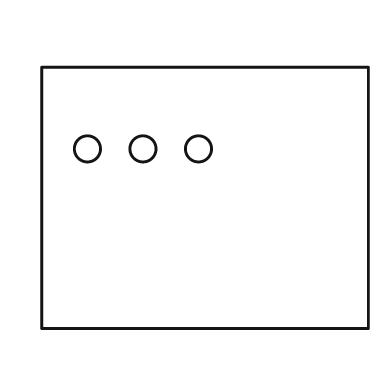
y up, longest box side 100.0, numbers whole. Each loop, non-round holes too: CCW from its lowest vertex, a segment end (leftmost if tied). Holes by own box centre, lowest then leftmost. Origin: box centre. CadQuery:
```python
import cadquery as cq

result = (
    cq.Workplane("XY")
    .moveTo(-50.0, -40.0)
    .lineTo(50.0, -40.0)
    .lineTo(50.0, 40.0)
    .lineTo(-50.0, 40.0)
    .close()
    .moveTo(-36.0, 15.0)
    .circle(4.0)
    .moveTo(-19.0, 15.0)
    .circle(4.0)
    .moveTo(-2.0, 15.0)
    .circle(4.0)
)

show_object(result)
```